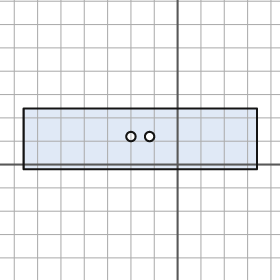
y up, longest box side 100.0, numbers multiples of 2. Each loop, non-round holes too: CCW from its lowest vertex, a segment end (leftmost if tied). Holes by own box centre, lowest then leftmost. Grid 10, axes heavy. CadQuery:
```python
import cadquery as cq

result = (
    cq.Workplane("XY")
    .moveTo(-66.0, -2.0)
    .lineTo(34.0, -2.0)
    .lineTo(34.0, 24.0)
    .lineTo(-66.0, 24.0)
    .close()
    .moveTo(-20.0, 12.0)
    .circle(2.0)
    .moveTo(-12.0, 12.0)
    .circle(2.0)
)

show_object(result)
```